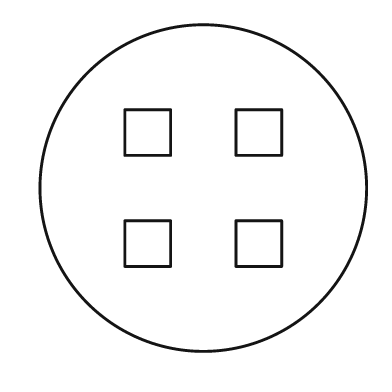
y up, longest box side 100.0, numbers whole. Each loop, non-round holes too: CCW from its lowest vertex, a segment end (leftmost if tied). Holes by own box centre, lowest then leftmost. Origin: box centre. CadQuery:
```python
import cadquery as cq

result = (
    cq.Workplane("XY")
    .moveTo(0.0, 0.0)
    .circle(50.0)
    .moveTo(-24.0, -24.0)
    .lineTo(-10.0, -24.0)
    .lineTo(-10.0, -10.0)
    .lineTo(-24.0, -10.0)
    .close()
    .moveTo(10.0, -24.0)
    .lineTo(24.0, -24.0)
    .lineTo(24.0, -10.0)
    .lineTo(10.0, -10.0)
    .close()
    .moveTo(-24.0, 10.0)
    .lineTo(-10.0, 10.0)
    .lineTo(-10.0, 24.0)
    .lineTo(-24.0, 24.0)
    .close()
    .moveTo(10.0, 10.0)
    .lineTo(24.0, 10.0)
    .lineTo(24.0, 24.0)
    .lineTo(10.0, 24.0)
    .close()
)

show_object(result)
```